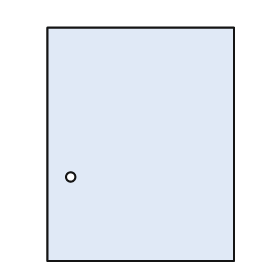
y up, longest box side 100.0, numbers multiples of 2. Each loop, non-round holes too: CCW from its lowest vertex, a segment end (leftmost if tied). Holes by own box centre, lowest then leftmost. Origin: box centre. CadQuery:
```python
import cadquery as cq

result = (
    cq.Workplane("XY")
    .moveTo(-40.0, -50.0)
    .lineTo(40.0, -50.0)
    .lineTo(40.0, 50.0)
    .lineTo(-40.0, 50.0)
    .close()
    .moveTo(-30.0, -14.0)
    .circle(2.0)
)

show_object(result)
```